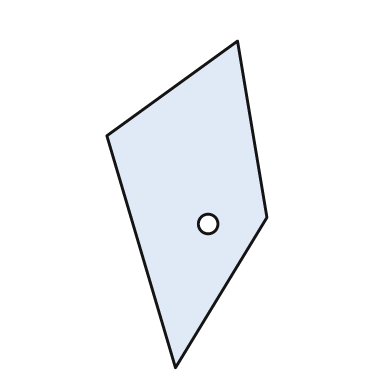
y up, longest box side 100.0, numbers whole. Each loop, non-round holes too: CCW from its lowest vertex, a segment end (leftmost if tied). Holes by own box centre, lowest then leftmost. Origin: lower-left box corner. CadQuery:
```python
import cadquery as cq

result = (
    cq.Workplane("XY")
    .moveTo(21.0, 0.0)
    .lineTo(49.0, 46.0)
    .lineTo(40.0, 100.0)
    .lineTo(0.0, 71.0)
    .close()
    .moveTo(31.0, 44.0)
    .circle(3.0)
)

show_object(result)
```